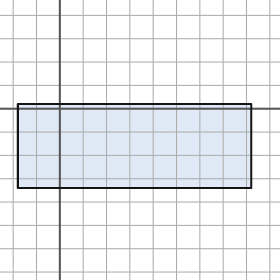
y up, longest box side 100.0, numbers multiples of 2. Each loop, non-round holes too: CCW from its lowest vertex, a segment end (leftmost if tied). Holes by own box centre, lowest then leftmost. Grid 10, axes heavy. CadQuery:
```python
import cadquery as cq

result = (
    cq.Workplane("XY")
    .moveTo(-18.0, -34.0)
    .lineTo(82.0, -34.0)
    .lineTo(82.0, 2.0)
    .lineTo(-18.0, 2.0)
    .close()
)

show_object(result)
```